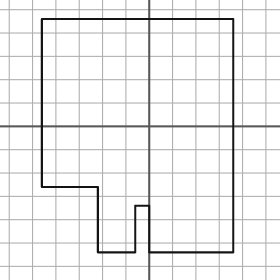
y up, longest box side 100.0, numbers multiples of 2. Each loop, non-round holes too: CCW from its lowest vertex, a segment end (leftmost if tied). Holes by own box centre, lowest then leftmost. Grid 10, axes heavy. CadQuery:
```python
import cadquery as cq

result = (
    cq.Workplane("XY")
    .moveTo(-22.0, -54.0)
    .lineTo(-6.0, -54.0)
    .lineTo(-6.0, -34.0)
    .lineTo(0.0, -34.0)
    .lineTo(0.0, -54.0)
    .lineTo(36.0, -54.0)
    .lineTo(36.0, 46.0)
    .lineTo(-46.0, 46.0)
    .lineTo(-46.0, -26.0)
    .lineTo(-22.0, -26.0)
    .close()
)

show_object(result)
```